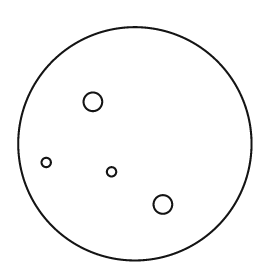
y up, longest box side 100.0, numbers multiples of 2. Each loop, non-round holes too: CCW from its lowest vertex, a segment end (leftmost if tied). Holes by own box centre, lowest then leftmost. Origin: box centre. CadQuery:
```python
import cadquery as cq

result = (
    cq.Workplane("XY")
    .moveTo(0.0, 0.0)
    .circle(50.0)
    .moveTo(12.0, -26.0)
    .circle(4.0)
    .moveTo(-10.0, -12.0)
    .circle(2.0)
    .moveTo(-38.0, -8.0)
    .circle(2.0)
    .moveTo(-18.0, 18.0)
    .circle(4.0)
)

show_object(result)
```